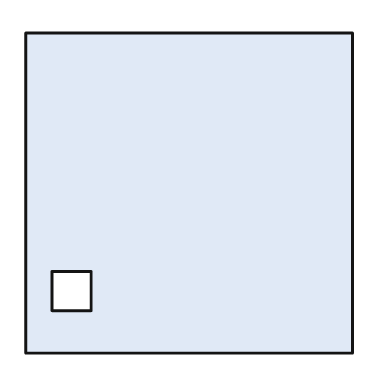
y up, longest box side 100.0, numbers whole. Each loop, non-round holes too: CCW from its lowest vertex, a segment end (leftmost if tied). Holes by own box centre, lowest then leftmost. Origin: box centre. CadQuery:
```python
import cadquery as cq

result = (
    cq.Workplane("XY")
    .moveTo(-50.0, -49.0)
    .lineTo(50.0, -49.0)
    .lineTo(50.0, 49.0)
    .lineTo(-50.0, 49.0)
    .close()
    .moveTo(-42.0, -36.0)
    .lineTo(-30.0, -36.0)
    .lineTo(-30.0, -24.0)
    .lineTo(-42.0, -24.0)
    .close()
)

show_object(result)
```